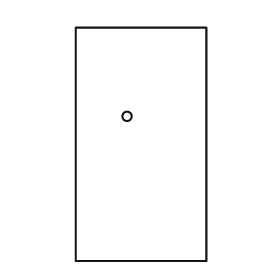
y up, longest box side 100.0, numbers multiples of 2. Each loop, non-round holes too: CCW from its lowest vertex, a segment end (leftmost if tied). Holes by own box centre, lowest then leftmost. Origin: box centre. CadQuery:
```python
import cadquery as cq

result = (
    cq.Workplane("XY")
    .moveTo(-28.0, -50.0)
    .lineTo(28.0, -50.0)
    .lineTo(28.0, 50.0)
    .lineTo(-28.0, 50.0)
    .close()
    .moveTo(-6.0, 12.0)
    .circle(2.0)
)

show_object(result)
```